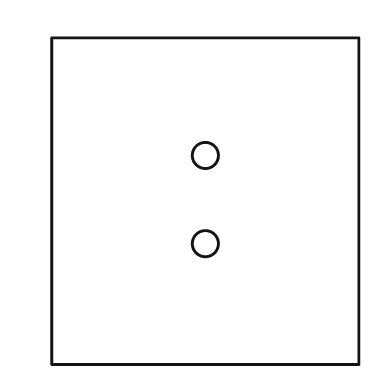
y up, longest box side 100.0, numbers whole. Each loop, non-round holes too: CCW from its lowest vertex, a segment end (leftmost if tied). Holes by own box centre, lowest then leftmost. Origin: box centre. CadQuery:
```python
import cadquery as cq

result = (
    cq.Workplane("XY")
    .moveTo(-47.0, -50.0)
    .lineTo(47.0, -50.0)
    .lineTo(47.0, 50.0)
    .lineTo(-47.0, 50.0)
    .close()
    .moveTo(0.0, -13.0)
    .circle(4.0)
    .moveTo(0.0, 14.0)
    .circle(4.0)
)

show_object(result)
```